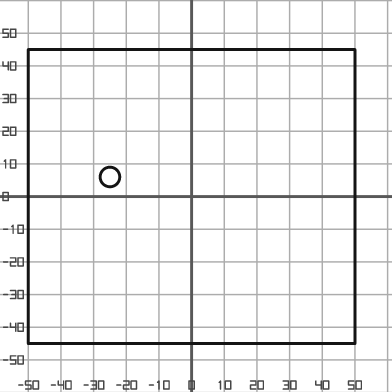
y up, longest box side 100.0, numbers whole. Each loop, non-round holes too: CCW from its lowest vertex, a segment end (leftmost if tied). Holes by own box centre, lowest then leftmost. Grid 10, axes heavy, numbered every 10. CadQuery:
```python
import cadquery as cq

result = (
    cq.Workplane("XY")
    .moveTo(-50.0, -45.0)
    .lineTo(50.0, -45.0)
    .lineTo(50.0, 45.0)
    .lineTo(-50.0, 45.0)
    .close()
    .moveTo(-25.0, 6.0)
    .circle(3.0)
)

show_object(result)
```